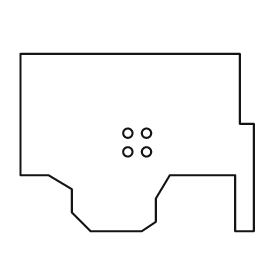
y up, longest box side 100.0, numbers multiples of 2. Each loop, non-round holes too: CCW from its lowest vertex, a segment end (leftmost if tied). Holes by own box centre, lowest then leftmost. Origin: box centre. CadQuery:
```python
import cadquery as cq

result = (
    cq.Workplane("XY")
    .moveTo(-20.0, -38.0)
    .lineTo(2.0, -38.0)
    .lineTo(8.0, -34.0)
    .lineTo(8.0, -24.0)
    .lineTo(14.0, -14.0)
    .lineTo(42.0, -14.0)
    .lineTo(42.0, -38.0)
    .lineTo(50.0, -38.0)
    .lineTo(50.0, 8.0)
    .lineTo(44.0, 8.0)
    .lineTo(44.0, 38.0)
    .lineTo(-50.0, 38.0)
    .lineTo(-50.0, -14.0)
    .lineTo(-38.0, -14.0)
    .lineTo(-28.0, -20.0)
    .lineTo(-28.0, -30.0)
    .close()
    .moveTo(-4.0, -4.0)
    .circle(2.0)
    .moveTo(4.0, -4.0)
    .circle(2.0)
    .moveTo(-4.0, 4.0)
    .circle(2.0)
    .moveTo(4.0, 4.0)
    .circle(2.0)
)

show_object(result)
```